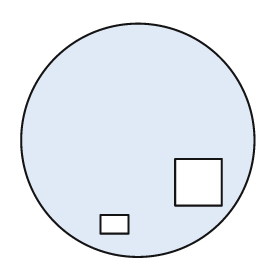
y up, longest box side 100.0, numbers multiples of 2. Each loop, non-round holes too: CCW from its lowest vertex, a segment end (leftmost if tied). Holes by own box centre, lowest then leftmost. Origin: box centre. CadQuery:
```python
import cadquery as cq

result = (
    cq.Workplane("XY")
    .moveTo(0.0, 0.0)
    .circle(50.0)
    .moveTo(-16.0, -40.0)
    .lineTo(-4.0, -40.0)
    .lineTo(-4.0, -32.0)
    .lineTo(-16.0, -32.0)
    .close()
    .moveTo(16.0, -28.0)
    .lineTo(36.0, -28.0)
    .lineTo(36.0, -8.0)
    .lineTo(16.0, -8.0)
    .close()
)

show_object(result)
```